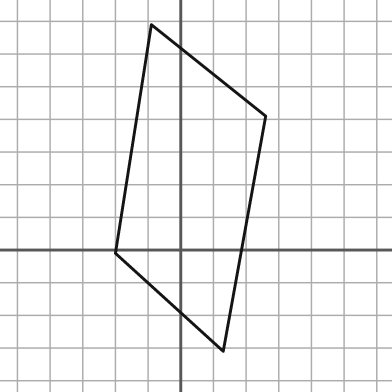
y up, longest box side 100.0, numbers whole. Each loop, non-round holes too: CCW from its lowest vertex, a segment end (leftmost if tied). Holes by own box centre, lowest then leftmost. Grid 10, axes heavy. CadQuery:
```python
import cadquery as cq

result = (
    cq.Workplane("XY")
    .moveTo(13.0, -31.0)
    .lineTo(26.0, 41.0)
    .lineTo(-9.0, 69.0)
    .lineTo(-20.0, -1.0)
    .close()
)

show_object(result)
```